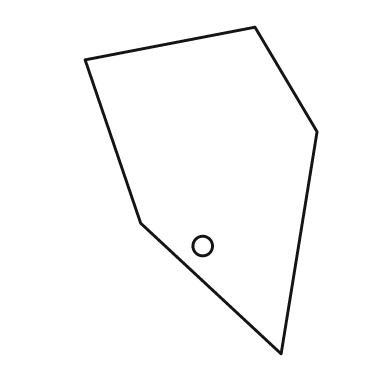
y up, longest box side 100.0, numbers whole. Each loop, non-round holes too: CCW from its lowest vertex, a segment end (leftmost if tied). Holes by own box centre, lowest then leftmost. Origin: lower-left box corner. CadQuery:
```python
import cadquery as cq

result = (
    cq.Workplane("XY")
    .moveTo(60.0, 0.0)
    .lineTo(71.0, 68.0)
    .lineTo(52.0, 100.0)
    .lineTo(0.0, 90.0)
    .lineTo(17.0, 40.0)
    .close()
    .moveTo(36.0, 33.0)
    .circle(3.0)
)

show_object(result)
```